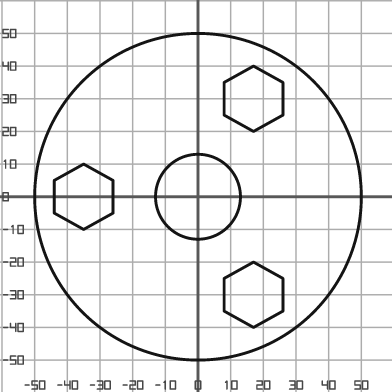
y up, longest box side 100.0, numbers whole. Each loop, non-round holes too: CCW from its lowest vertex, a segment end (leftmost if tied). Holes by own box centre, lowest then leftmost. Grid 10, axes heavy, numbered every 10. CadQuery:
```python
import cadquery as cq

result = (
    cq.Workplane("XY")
    .moveTo(0.0, 0.0)
    .circle(50.0)
    .moveTo(17.0, -40.0)
    .lineTo(26.0, -35.0)
    .lineTo(26.0, -25.0)
    .lineTo(17.0, -20.0)
    .lineTo(8.0, -25.0)
    .lineTo(8.0, -35.0)
    .close()
    .moveTo(-35.0, -10.0)
    .lineTo(-26.0, -5.0)
    .lineTo(-26.0, 5.0)
    .lineTo(-35.0, 10.0)
    .lineTo(-44.0, 5.0)
    .lineTo(-44.0, -5.0)
    .close()
    .moveTo(0.0, 0.0)
    .circle(13.0)
    .moveTo(17.0, 20.0)
    .lineTo(26.0, 25.0)
    .lineTo(26.0, 35.0)
    .lineTo(17.0, 40.0)
    .lineTo(8.0, 35.0)
    .lineTo(8.0, 25.0)
    .close()
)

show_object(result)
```